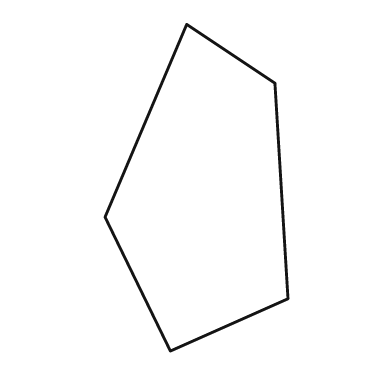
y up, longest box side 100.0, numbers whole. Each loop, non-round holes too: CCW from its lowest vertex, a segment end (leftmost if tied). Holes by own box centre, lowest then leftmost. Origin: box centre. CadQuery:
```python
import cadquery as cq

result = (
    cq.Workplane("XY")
    .moveTo(-8.0, -50.0)
    .lineTo(28.0, -34.0)
    .lineTo(24.0, 32.0)
    .lineTo(-3.0, 50.0)
    .lineTo(-28.0, -9.0)
    .close()
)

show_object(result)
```